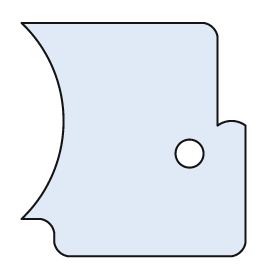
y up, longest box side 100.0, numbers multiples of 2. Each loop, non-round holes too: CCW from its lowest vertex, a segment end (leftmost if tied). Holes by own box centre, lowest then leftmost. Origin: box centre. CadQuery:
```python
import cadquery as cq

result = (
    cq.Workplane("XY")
    .moveTo(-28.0, -50.0)
    .lineTo(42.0, -50.0)
    .threePointArc((46.0, -48.0), (48.0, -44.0))
    .lineTo(48.0, 6.0)
    .threePointArc((42.0, 8.0), (36.0, 6.0))
    .lineTo(36.0, 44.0)
    .threePointArc((34.0, 48.0), (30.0, 50.0))
    .lineTo(-48.0, 50.0)
    .threePointArc((-30.0, 8.0), (-48.0, -34.0))
    .lineTo(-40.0, -34.0)
    .threePointArc((-36.0, -36.0), (-34.0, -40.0))
    .lineTo(-34.0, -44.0)
    .threePointArc((-32.0, -48.0), (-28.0, -50.0))
    .close()
    .moveTo(24.0, -6.0)
    .circle(6.0)
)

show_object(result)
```